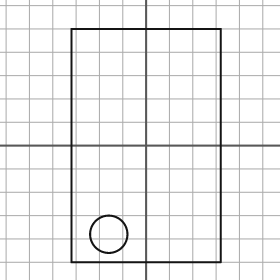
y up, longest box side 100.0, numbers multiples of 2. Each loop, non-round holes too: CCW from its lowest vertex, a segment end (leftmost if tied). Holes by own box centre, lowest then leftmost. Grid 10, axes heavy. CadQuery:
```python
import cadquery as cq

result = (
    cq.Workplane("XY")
    .moveTo(-32.0, -50.0)
    .lineTo(32.0, -50.0)
    .lineTo(32.0, 50.0)
    .lineTo(-32.0, 50.0)
    .close()
    .moveTo(-16.0, -38.0)
    .circle(8.0)
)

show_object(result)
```